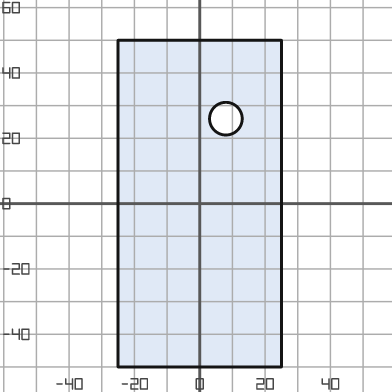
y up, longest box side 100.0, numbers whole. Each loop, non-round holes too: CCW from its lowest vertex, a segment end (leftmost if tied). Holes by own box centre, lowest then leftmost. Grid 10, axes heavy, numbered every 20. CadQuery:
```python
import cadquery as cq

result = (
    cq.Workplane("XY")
    .moveTo(-25.0, -50.0)
    .lineTo(25.0, -50.0)
    .lineTo(25.0, 50.0)
    .lineTo(-25.0, 50.0)
    .close()
    .moveTo(8.0, 26.0)
    .circle(5.0)
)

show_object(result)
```